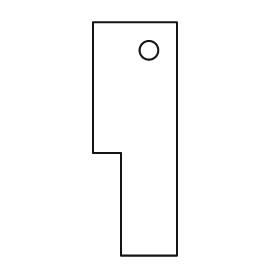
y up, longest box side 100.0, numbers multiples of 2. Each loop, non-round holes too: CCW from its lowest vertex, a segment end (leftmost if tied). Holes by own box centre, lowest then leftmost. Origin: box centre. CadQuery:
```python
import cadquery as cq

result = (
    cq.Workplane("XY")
    .moveTo(-6.0, -50.0)
    .lineTo(18.0, -50.0)
    .lineTo(18.0, 50.0)
    .lineTo(-18.0, 50.0)
    .lineTo(-18.0, -6.0)
    .lineTo(-6.0, -6.0)
    .close()
    .moveTo(6.0, 38.0)
    .circle(4.0)
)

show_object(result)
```